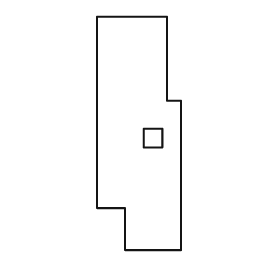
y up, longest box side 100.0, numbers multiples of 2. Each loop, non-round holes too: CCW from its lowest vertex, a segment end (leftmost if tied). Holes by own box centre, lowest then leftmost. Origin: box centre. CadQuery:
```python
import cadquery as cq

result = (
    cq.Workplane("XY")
    .moveTo(-6.0, -50.0)
    .lineTo(18.0, -50.0)
    .lineTo(18.0, 14.0)
    .lineTo(12.0, 14.0)
    .lineTo(12.0, 50.0)
    .lineTo(-18.0, 50.0)
    .lineTo(-18.0, -32.0)
    .lineTo(-6.0, -32.0)
    .close()
    .moveTo(2.0, -6.0)
    .lineTo(10.0, -6.0)
    .lineTo(10.0, 2.0)
    .lineTo(2.0, 2.0)
    .close()
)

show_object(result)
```